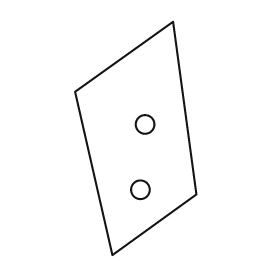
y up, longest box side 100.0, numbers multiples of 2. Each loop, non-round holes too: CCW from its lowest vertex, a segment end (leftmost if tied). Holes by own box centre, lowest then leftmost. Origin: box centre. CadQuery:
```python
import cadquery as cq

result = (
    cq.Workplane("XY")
    .moveTo(-10.0, -50.0)
    .lineTo(26.0, -24.0)
    .lineTo(16.0, 50.0)
    .lineTo(-26.0, 20.0)
    .close()
    .moveTo(2.0, -22.0)
    .circle(4.0)
    .moveTo(4.0, 6.0)
    .circle(4.0)
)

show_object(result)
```